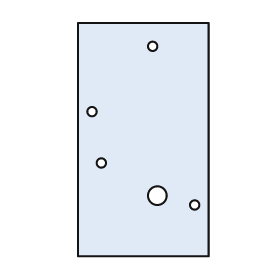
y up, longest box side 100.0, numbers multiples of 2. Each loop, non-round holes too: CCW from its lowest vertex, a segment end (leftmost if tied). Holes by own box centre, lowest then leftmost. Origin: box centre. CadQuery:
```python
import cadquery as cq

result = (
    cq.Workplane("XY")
    .moveTo(-28.0, -50.0)
    .lineTo(28.0, -50.0)
    .lineTo(28.0, 50.0)
    .lineTo(-28.0, 50.0)
    .close()
    .moveTo(22.0, -28.0)
    .circle(2.0)
    .moveTo(6.0, -24.0)
    .circle(4.0)
    .moveTo(-18.0, -10.0)
    .circle(2.0)
    .moveTo(-22.0, 12.0)
    .circle(2.0)
    .moveTo(4.0, 40.0)
    .circle(2.0)
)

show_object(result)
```